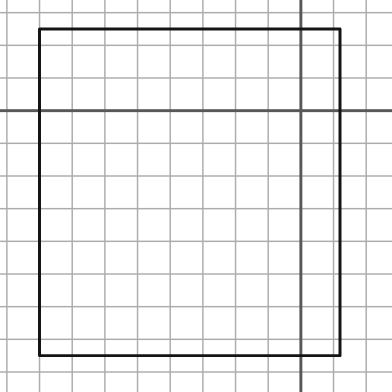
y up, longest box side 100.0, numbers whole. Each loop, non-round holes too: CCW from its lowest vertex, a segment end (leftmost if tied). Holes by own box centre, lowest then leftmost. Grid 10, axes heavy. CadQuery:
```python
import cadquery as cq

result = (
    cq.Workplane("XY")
    .moveTo(-80.0, -75.0)
    .lineTo(12.0, -75.0)
    .lineTo(12.0, 25.0)
    .lineTo(-80.0, 25.0)
    .close()
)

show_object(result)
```